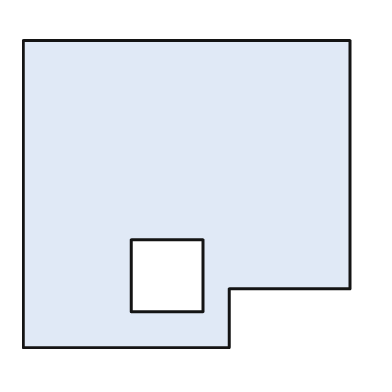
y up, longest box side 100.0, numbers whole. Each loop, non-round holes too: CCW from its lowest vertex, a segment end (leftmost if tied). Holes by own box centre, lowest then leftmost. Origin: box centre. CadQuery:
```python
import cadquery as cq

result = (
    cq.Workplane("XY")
    .moveTo(-50.0, -47.0)
    .lineTo(13.0, -47.0)
    .lineTo(13.0, -29.0)
    .lineTo(50.0, -29.0)
    .lineTo(50.0, 47.0)
    .lineTo(-50.0, 47.0)
    .close()
    .moveTo(-17.0, -36.0)
    .lineTo(5.0, -36.0)
    .lineTo(5.0, -14.0)
    .lineTo(-17.0, -14.0)
    .close()
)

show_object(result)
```